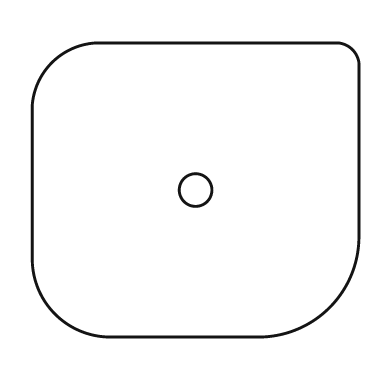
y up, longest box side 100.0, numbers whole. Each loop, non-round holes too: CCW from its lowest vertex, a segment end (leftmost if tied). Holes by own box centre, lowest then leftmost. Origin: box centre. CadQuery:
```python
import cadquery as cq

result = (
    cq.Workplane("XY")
    .moveTo(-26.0, -45.0)
    .lineTo(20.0, -45.0)
    .threePointArc((41.0, -36.0), (50.0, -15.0))
    .lineTo(50.0, 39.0)
    .threePointArc((48.0, 43.0), (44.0, 45.0))
    .lineTo(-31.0, 45.0)
    .threePointArc((-44.0, 39.0), (-50.0, 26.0))
    .lineTo(-50.0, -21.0)
    .threePointArc((-43.0, -38.0), (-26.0, -45.0))
    .close()
    .moveTo(0.0, 0.0)
    .circle(5.0)
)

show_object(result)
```